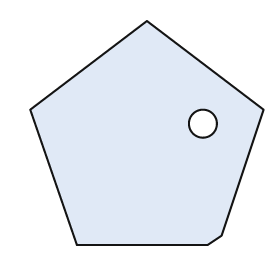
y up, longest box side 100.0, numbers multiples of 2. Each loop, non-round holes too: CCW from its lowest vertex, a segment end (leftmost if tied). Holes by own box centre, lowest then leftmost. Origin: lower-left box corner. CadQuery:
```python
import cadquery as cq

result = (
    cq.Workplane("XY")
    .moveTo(20.0, 0.0)
    .lineTo(76.0, 0.0)
    .lineTo(82.0, 4.0)
    .lineTo(100.0, 58.0)
    .lineTo(50.0, 96.0)
    .lineTo(0.0, 58.0)
    .close()
    .moveTo(74.0, 52.0)
    .circle(6.0)
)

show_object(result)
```